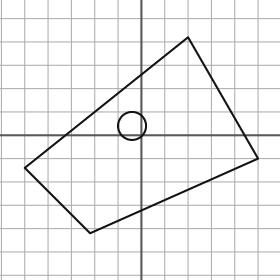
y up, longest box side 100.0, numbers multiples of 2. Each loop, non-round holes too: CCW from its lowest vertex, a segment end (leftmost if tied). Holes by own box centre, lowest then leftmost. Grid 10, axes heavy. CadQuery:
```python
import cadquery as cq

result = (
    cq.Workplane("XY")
    .moveTo(-22.0, -42.0)
    .lineTo(50.0, -10.0)
    .lineTo(20.0, 42.0)
    .lineTo(-50.0, -14.0)
    .close()
    .moveTo(-4.0, 4.0)
    .circle(6.0)
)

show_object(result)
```